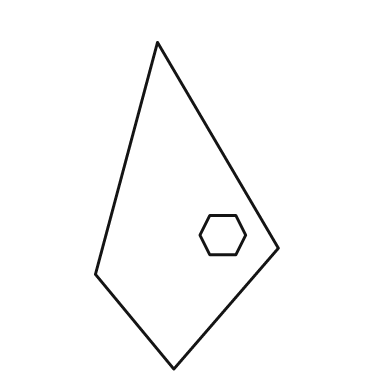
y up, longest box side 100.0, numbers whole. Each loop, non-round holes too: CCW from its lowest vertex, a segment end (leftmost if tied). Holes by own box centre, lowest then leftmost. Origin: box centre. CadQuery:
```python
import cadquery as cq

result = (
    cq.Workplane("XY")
    .moveTo(-4.0, -50.0)
    .lineTo(28.0, -13.0)
    .lineTo(-9.0, 50.0)
    .lineTo(-28.0, -21.0)
    .close()
    .moveTo(7.0, -15.0)
    .lineTo(15.0, -15.0)
    .lineTo(18.0, -9.0)
    .lineTo(15.0, -3.0)
    .lineTo(7.0, -3.0)
    .lineTo(4.0, -9.0)
    .close()
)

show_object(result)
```